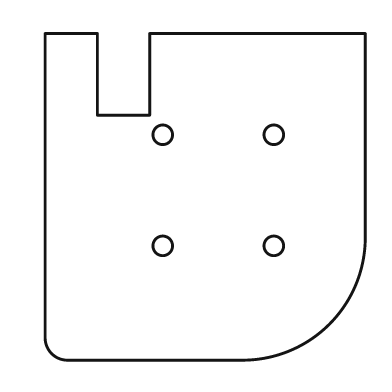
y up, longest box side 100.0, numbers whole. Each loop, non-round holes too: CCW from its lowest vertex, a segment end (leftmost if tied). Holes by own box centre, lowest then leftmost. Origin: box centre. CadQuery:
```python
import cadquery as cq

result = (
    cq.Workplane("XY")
    .moveTo(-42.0, -50.0)
    .lineTo(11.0, -50.0)
    .threePointArc((38.0, -39.0), (49.0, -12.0))
    .lineTo(49.0, 50.0)
    .lineTo(-17.0, 50.0)
    .lineTo(-17.0, 25.0)
    .lineTo(-33.0, 25.0)
    .lineTo(-33.0, 50.0)
    .lineTo(-49.0, 50.0)
    .lineTo(-49.0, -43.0)
    .threePointArc((-47.0, -48.0), (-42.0, -50.0))
    .close()
    .moveTo(-13.0, -15.0)
    .circle(3.0)
    .moveTo(21.0, -15.0)
    .circle(3.0)
    .moveTo(-13.0, 19.0)
    .circle(3.0)
    .moveTo(21.0, 19.0)
    .circle(3.0)
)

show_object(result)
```